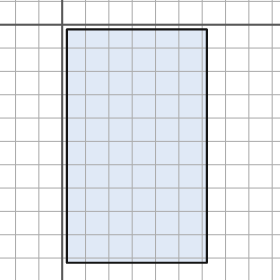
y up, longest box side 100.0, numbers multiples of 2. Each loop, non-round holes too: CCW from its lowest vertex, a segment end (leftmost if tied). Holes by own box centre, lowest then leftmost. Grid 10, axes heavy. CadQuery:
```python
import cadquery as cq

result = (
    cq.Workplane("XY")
    .moveTo(2.0, -102.0)
    .lineTo(62.0, -102.0)
    .lineTo(62.0, -2.0)
    .lineTo(2.0, -2.0)
    .close()
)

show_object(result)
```